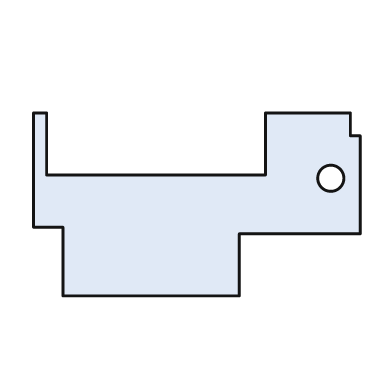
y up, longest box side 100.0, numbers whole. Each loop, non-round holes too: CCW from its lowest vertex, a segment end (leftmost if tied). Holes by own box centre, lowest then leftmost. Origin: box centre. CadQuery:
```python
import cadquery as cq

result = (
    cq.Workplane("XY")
    .moveTo(-41.0, -28.0)
    .lineTo(13.0, -28.0)
    .lineTo(13.0, -9.0)
    .lineTo(50.0, -9.0)
    .lineTo(50.0, 21.0)
    .lineTo(47.0, 21.0)
    .lineTo(47.0, 28.0)
    .lineTo(21.0, 28.0)
    .lineTo(21.0, 9.0)
    .lineTo(-46.0, 9.0)
    .lineTo(-46.0, 28.0)
    .lineTo(-50.0, 28.0)
    .lineTo(-50.0, -7.0)
    .lineTo(-41.0, -7.0)
    .close()
    .moveTo(41.0, 8.0)
    .circle(4.0)
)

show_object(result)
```